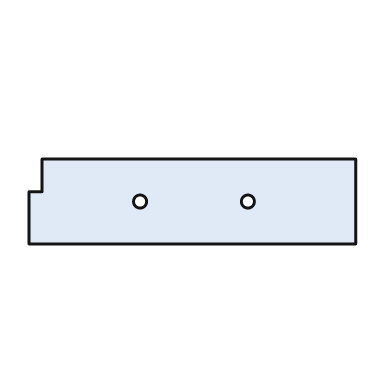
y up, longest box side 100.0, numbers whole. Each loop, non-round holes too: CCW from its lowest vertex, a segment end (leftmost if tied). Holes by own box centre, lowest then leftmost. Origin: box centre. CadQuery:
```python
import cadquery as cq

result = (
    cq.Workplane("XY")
    .moveTo(-50.0, -13.0)
    .lineTo(50.0, -13.0)
    .lineTo(50.0, 13.0)
    .lineTo(-46.0, 13.0)
    .lineTo(-46.0, 3.0)
    .lineTo(-50.0, 3.0)
    .close()
    .moveTo(-16.0, 0.0)
    .circle(2.0)
    .moveTo(17.0, 0.0)
    .circle(2.0)
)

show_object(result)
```